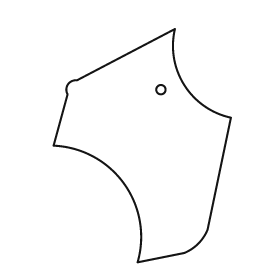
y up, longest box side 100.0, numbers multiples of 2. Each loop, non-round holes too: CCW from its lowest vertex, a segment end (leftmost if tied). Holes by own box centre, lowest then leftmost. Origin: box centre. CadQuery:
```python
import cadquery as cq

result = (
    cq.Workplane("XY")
    .moveTo(-2.0, -50.0)
    .lineTo(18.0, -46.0)
    .threePointArc((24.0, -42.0), (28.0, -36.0))
    .lineTo(38.0, 12.0)
    .threePointArc((18.0, 26.0), (14.0, 50.0))
    .lineTo(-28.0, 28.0)
    .threePointArc((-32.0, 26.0), (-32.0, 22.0))
    .lineTo(-38.0, 0.0)
    .threePointArc((-8.0, -16.0), (-2.0, -50.0))
    .close()
    .moveTo(8.0, 24.0)
    .circle(2.0)
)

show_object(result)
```